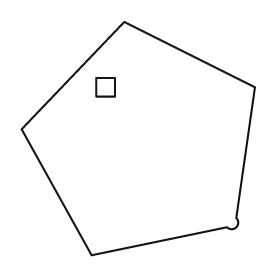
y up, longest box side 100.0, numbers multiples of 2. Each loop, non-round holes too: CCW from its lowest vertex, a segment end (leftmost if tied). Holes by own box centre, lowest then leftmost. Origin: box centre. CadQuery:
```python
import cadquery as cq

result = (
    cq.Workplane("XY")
    .moveTo(-20.0, -50.0)
    .lineTo(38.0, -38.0)
    .threePointArc((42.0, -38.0), (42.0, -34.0))
    .lineTo(50.0, 22.0)
    .lineTo(-6.0, 50.0)
    .lineTo(-50.0, 4.0)
    .close()
    .moveTo(-18.0, 18.0)
    .lineTo(-10.0, 18.0)
    .lineTo(-10.0, 26.0)
    .lineTo(-18.0, 26.0)
    .close()
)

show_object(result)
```